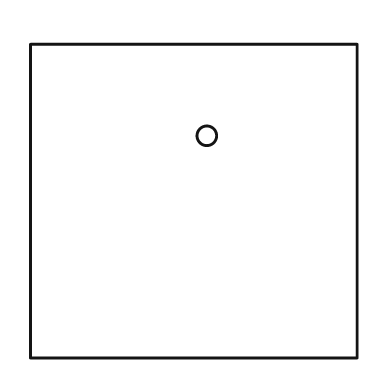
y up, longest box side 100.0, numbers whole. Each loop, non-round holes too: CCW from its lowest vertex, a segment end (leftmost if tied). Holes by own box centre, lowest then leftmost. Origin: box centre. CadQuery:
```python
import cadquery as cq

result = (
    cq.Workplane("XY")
    .moveTo(-50.0, -48.0)
    .lineTo(50.0, -48.0)
    .lineTo(50.0, 48.0)
    .lineTo(-50.0, 48.0)
    .close()
    .moveTo(4.0, 20.0)
    .circle(3.0)
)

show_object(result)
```